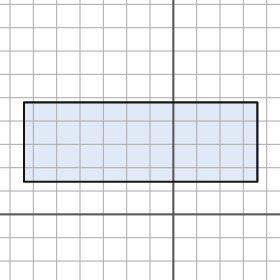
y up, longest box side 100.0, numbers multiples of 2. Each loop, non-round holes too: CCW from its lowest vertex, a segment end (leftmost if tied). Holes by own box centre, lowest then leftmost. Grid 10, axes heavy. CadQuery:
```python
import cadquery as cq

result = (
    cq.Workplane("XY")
    .moveTo(-64.0, 14.0)
    .lineTo(36.0, 14.0)
    .lineTo(36.0, 48.0)
    .lineTo(-64.0, 48.0)
    .close()
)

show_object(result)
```